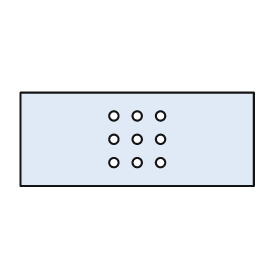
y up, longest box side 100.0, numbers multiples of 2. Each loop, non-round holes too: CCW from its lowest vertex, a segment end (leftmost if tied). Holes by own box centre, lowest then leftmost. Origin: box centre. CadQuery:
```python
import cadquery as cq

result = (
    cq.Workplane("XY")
    .moveTo(-50.0, -20.0)
    .lineTo(50.0, -20.0)
    .lineTo(50.0, 20.0)
    .lineTo(-50.0, 20.0)
    .close()
    .moveTo(-10.0, -10.0)
    .circle(2.0)
    .moveTo(0.0, -10.0)
    .circle(2.0)
    .moveTo(10.0, -10.0)
    .circle(2.0)
    .moveTo(-10.0, 0.0)
    .circle(2.0)
    .moveTo(0.0, 0.0)
    .circle(2.0)
    .moveTo(10.0, 0.0)
    .circle(2.0)
    .moveTo(-10.0, 10.0)
    .circle(2.0)
    .moveTo(0.0, 10.0)
    .circle(2.0)
    .moveTo(10.0, 10.0)
    .circle(2.0)
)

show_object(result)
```